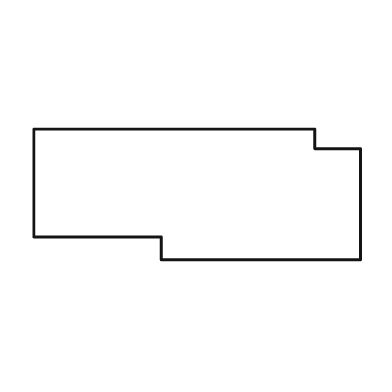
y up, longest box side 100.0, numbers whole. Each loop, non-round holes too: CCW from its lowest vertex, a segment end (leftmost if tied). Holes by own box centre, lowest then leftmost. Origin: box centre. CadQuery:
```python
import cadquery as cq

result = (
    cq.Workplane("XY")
    .moveTo(-11.0, -20.0)
    .lineTo(50.0, -20.0)
    .lineTo(50.0, 14.0)
    .lineTo(36.0, 14.0)
    .lineTo(36.0, 20.0)
    .lineTo(-50.0, 20.0)
    .lineTo(-50.0, -13.0)
    .lineTo(-11.0, -13.0)
    .close()
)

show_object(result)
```